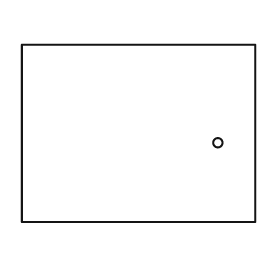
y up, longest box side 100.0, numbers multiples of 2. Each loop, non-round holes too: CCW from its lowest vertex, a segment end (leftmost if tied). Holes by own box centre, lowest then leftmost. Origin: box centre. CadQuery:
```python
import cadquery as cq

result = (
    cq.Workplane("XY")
    .moveTo(-50.0, -38.0)
    .lineTo(50.0, -38.0)
    .lineTo(50.0, 38.0)
    .lineTo(-50.0, 38.0)
    .close()
    .moveTo(34.0, -4.0)
    .circle(2.0)
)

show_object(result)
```